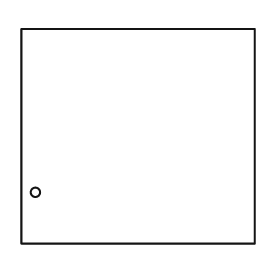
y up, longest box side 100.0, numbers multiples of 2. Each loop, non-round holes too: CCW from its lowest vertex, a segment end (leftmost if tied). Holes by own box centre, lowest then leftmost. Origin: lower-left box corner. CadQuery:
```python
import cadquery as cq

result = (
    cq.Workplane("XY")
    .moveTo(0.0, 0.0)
    .lineTo(100.0, 0.0)
    .lineTo(100.0, 92.0)
    .lineTo(0.0, 92.0)
    .close()
    .moveTo(6.0, 22.0)
    .circle(2.0)
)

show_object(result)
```